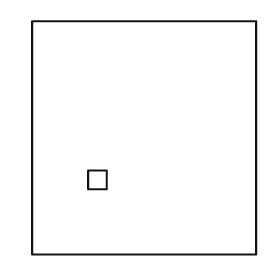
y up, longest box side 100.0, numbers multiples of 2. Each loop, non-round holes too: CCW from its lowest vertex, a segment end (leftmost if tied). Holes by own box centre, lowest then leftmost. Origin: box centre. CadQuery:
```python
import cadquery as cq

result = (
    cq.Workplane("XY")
    .moveTo(-48.0, -50.0)
    .lineTo(48.0, -50.0)
    .lineTo(48.0, 50.0)
    .lineTo(-48.0, 50.0)
    .close()
    .moveTo(-24.0, -22.0)
    .lineTo(-16.0, -22.0)
    .lineTo(-16.0, -14.0)
    .lineTo(-24.0, -14.0)
    .close()
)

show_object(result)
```